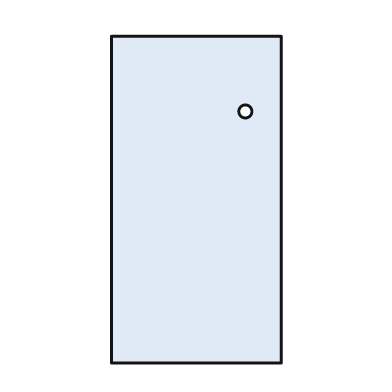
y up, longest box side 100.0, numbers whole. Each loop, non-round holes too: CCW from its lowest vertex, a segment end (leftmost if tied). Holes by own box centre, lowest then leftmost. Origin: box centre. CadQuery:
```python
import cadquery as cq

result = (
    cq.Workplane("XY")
    .moveTo(-26.0, -50.0)
    .lineTo(26.0, -50.0)
    .lineTo(26.0, 50.0)
    .lineTo(-26.0, 50.0)
    .close()
    .moveTo(15.0, 27.0)
    .circle(2.0)
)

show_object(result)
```